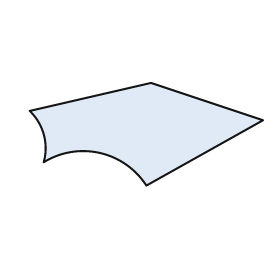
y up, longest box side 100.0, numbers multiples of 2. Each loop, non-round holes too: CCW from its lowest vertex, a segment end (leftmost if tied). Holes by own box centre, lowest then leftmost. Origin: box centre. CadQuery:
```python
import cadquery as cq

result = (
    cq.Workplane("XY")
    .moveTo(0.0, -22.0)
    .lineTo(50.0, 6.0)
    .lineTo(2.0, 22.0)
    .lineTo(-50.0, 10.0)
    .threePointArc((-44.0, 0.0), (-44.0, -12.0))
    .threePointArc((-20.0, -8.0), (0.0, -22.0))
    .close()
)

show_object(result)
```